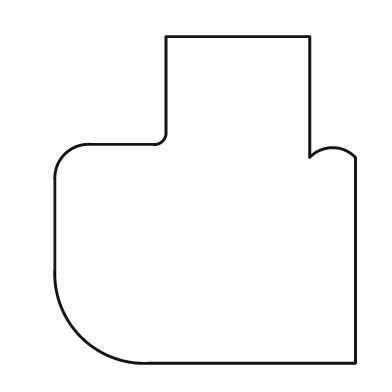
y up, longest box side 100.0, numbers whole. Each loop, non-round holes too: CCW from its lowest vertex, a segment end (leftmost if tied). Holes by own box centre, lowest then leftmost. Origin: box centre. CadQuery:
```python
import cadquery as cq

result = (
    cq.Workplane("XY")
    .moveTo(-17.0, -50.0)
    .lineTo(46.0, -50.0)
    .lineTo(46.0, 13.0)
    .threePointArc((39.0, 16.0), (32.0, 13.0))
    .lineTo(32.0, 50.0)
    .lineTo(-12.0, 50.0)
    .lineTo(-12.0, 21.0)
    .threePointArc((-13.0, 18.0), (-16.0, 17.0))
    .lineTo(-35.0, 17.0)
    .threePointArc((-43.0, 14.0), (-46.0, 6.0))
    .lineTo(-46.0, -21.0)
    .threePointArc((-38.0, -42.0), (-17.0, -50.0))
    .close()
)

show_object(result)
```